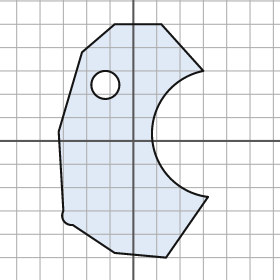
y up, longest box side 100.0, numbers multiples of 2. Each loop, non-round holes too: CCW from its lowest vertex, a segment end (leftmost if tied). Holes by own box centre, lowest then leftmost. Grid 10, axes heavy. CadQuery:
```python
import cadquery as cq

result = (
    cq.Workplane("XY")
    .moveTo(14.0, -50.0)
    .lineTo(32.0, -24.0)
    .threePointArc((8.0, 2.0), (30.0, 30.0))
    .lineTo(12.0, 50.0)
    .lineTo(-8.0, 50.0)
    .lineTo(-22.0, 38.0)
    .lineTo(-32.0, 4.0)
    .lineTo(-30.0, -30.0)
    .threePointArc((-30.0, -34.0), (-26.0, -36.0))
    .lineTo(-8.0, -48.0)
    .close()
    .moveTo(-12.0, 24.0)
    .circle(6.0)
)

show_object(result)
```